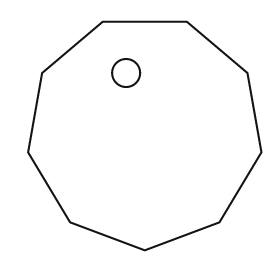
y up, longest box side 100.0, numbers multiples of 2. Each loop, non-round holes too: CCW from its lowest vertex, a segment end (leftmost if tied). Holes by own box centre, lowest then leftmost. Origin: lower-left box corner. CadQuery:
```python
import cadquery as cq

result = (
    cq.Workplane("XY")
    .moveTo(50.0, 0.0)
    .lineTo(82.0, 12.0)
    .lineTo(100.0, 42.0)
    .lineTo(94.0, 76.0)
    .lineTo(68.0, 98.0)
    .lineTo(32.0, 98.0)
    .lineTo(6.0, 76.0)
    .lineTo(0.0, 42.0)
    .lineTo(18.0, 12.0)
    .close()
    .moveTo(42.0, 76.0)
    .circle(6.0)
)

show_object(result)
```